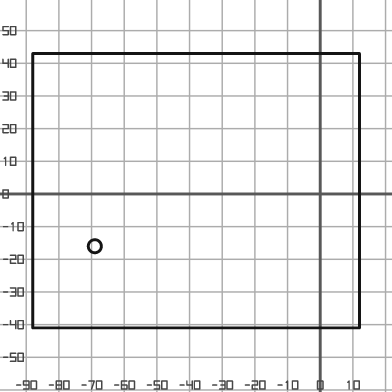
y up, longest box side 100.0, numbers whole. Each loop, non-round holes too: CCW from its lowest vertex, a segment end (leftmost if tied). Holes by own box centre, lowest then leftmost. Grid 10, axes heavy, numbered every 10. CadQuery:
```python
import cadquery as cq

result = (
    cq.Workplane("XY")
    .moveTo(-88.0, -41.0)
    .lineTo(12.0, -41.0)
    .lineTo(12.0, 43.0)
    .lineTo(-88.0, 43.0)
    .close()
    .moveTo(-69.0, -16.0)
    .circle(2.0)
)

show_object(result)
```